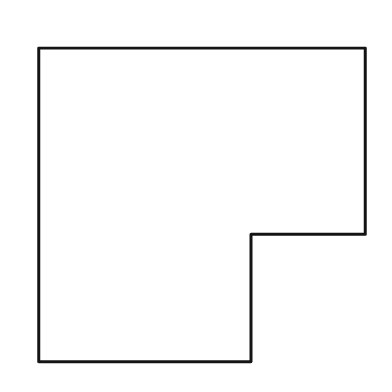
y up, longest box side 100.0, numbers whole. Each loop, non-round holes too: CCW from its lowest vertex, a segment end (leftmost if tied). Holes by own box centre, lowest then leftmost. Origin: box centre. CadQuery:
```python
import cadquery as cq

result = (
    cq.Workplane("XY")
    .moveTo(-50.0, -48.0)
    .lineTo(15.0, -48.0)
    .lineTo(15.0, -9.0)
    .lineTo(50.0, -9.0)
    .lineTo(50.0, 48.0)
    .lineTo(-50.0, 48.0)
    .close()
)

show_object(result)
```